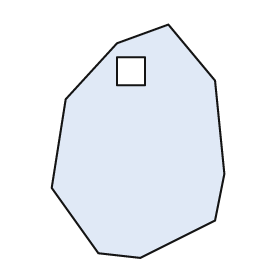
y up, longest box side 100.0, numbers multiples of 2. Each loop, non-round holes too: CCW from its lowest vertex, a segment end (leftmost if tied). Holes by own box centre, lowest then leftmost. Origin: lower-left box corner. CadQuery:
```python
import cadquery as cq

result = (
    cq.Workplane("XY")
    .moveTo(38.0, 0.0)
    .lineTo(70.0, 16.0)
    .lineTo(74.0, 36.0)
    .lineTo(70.0, 76.0)
    .lineTo(50.0, 100.0)
    .lineTo(28.0, 92.0)
    .lineTo(6.0, 68.0)
    .lineTo(0.0, 30.0)
    .lineTo(20.0, 2.0)
    .close()
    .moveTo(28.0, 74.0)
    .lineTo(40.0, 74.0)
    .lineTo(40.0, 86.0)
    .lineTo(28.0, 86.0)
    .close()
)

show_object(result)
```